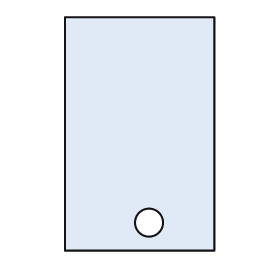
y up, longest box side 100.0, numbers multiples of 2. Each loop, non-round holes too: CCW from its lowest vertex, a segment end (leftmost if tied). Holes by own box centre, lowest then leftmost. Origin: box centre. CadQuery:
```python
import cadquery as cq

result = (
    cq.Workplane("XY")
    .moveTo(-32.0, -50.0)
    .lineTo(32.0, -50.0)
    .lineTo(32.0, 50.0)
    .lineTo(-32.0, 50.0)
    .close()
    .moveTo(4.0, -38.0)
    .circle(6.0)
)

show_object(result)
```